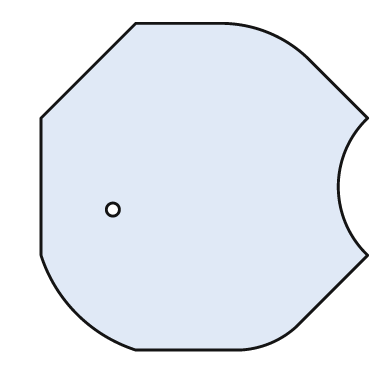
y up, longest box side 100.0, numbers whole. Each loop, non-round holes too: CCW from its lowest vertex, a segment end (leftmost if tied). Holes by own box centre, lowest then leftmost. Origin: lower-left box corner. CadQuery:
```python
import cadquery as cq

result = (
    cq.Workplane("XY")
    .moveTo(29.0, 0.0)
    .lineTo(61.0, 0.0)
    .threePointArc((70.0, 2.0), (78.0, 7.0))
    .lineTo(100.0, 29.0)
    .threePointArc((91.0, 50.0), (100.0, 71.0))
    .lineTo(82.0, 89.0)
    .threePointArc((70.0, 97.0), (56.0, 100.0))
    .lineTo(29.0, 100.0)
    .lineTo(0.0, 71.0)
    .lineTo(0.0, 29.0)
    .threePointArc((11.0, 11.0), (29.0, 0.0))
    .close()
    .moveTo(22.0, 43.0)
    .circle(2.0)
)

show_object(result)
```